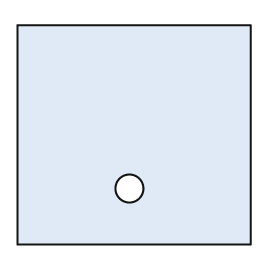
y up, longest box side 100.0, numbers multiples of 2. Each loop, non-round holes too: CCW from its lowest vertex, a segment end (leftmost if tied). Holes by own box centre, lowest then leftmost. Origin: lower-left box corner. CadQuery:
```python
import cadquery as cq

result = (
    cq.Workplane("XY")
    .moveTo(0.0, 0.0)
    .lineTo(100.0, 0.0)
    .lineTo(100.0, 94.0)
    .lineTo(0.0, 94.0)
    .close()
    .moveTo(48.0, 24.0)
    .circle(6.0)
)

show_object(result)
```